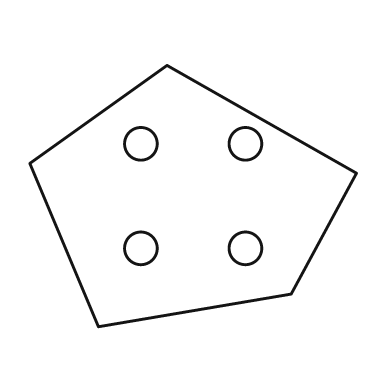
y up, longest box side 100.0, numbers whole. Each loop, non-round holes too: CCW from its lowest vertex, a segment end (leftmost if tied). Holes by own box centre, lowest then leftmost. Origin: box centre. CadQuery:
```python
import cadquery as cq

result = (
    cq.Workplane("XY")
    .moveTo(-29.0, -40.0)
    .lineTo(30.0, -30.0)
    .lineTo(50.0, 7.0)
    .lineTo(-8.0, 40.0)
    .lineTo(-50.0, 10.0)
    .close()
    .moveTo(-16.0, -16.0)
    .circle(5.0)
    .moveTo(16.0, -16.0)
    .circle(5.0)
    .moveTo(-16.0, 16.0)
    .circle(5.0)
    .moveTo(16.0, 16.0)
    .circle(5.0)
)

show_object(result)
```